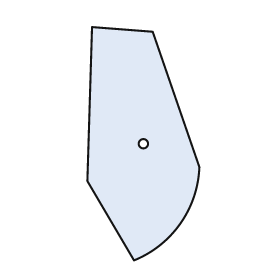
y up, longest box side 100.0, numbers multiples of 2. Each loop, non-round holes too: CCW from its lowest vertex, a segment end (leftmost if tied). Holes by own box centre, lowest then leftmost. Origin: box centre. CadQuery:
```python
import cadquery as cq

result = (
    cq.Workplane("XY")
    .moveTo(-4.0, -50.0)
    .threePointArc((16.0, -34.0), (24.0, -10.0))
    .lineTo(4.0, 48.0)
    .lineTo(-22.0, 50.0)
    .lineTo(-24.0, -16.0)
    .close()
    .moveTo(0.0, 0.0)
    .circle(2.0)
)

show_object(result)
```